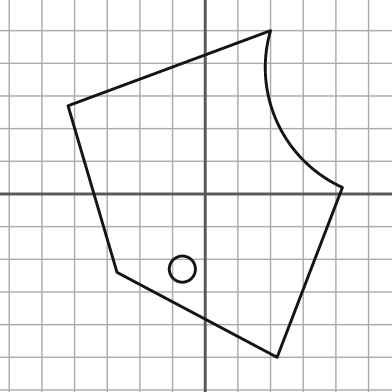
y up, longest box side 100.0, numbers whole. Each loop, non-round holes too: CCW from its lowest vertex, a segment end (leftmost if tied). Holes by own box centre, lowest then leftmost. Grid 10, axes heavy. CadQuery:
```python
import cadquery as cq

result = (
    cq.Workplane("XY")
    .moveTo(22.0, -50.0)
    .lineTo(42.0, 2.0)
    .threePointArc((22.0, 22.0), (20.0, 50.0))
    .lineTo(-42.0, 27.0)
    .lineTo(-27.0, -24.0)
    .close()
    .moveTo(-7.0, -23.0)
    .circle(4.0)
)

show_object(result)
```